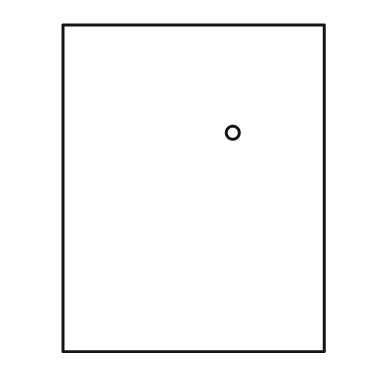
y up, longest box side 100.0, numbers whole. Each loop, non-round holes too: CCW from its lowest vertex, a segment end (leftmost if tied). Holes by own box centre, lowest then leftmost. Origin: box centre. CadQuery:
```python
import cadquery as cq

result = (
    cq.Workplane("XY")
    .moveTo(-40.0, -50.0)
    .lineTo(40.0, -50.0)
    .lineTo(40.0, 50.0)
    .lineTo(-40.0, 50.0)
    .close()
    .moveTo(12.0, 17.0)
    .circle(2.0)
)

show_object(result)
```